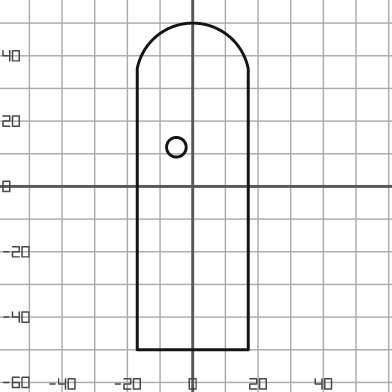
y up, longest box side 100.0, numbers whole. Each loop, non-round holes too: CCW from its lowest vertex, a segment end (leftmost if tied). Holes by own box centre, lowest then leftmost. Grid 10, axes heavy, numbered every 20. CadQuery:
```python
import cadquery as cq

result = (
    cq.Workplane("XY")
    .moveTo(-17.0, -50.0)
    .lineTo(17.0, -50.0)
    .lineTo(17.0, 36.0)
    .threePointArc((0.0, 50.0), (-17.0, 36.0))
    .close()
    .moveTo(-5.0, 12.0)
    .circle(3.0)
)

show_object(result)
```